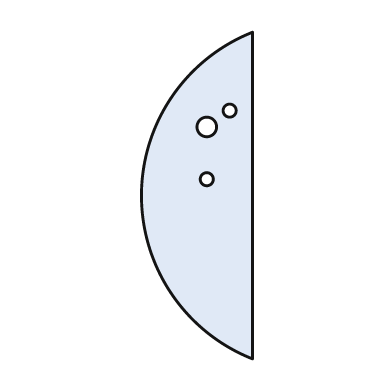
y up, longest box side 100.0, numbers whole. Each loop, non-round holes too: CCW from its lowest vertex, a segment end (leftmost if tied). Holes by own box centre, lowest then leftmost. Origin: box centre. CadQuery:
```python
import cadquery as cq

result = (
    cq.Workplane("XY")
    .moveTo(17.0, -50.0)
    .lineTo(17.0, 50.0)
    .threePointArc((-17.0, 0.0), (17.0, -50.0))
    .close()
    .moveTo(3.0, 5.0)
    .circle(2.0)
    .moveTo(3.0, 21.0)
    .circle(3.0)
    .moveTo(10.0, 26.0)
    .circle(2.0)
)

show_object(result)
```